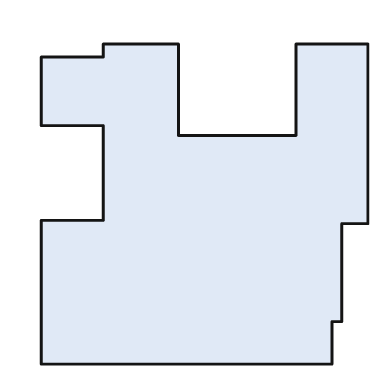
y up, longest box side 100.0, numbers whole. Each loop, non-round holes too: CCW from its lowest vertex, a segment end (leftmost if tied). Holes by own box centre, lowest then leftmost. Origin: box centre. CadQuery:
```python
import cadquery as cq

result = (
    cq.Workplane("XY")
    .moveTo(-50.0, -49.0)
    .lineTo(39.0, -49.0)
    .lineTo(39.0, -36.0)
    .lineTo(42.0, -36.0)
    .lineTo(42.0, -6.0)
    .lineTo(50.0, -6.0)
    .lineTo(50.0, 49.0)
    .lineTo(28.0, 49.0)
    .lineTo(28.0, 21.0)
    .lineTo(-8.0, 21.0)
    .lineTo(-8.0, 49.0)
    .lineTo(-31.0, 49.0)
    .lineTo(-31.0, 45.0)
    .lineTo(-50.0, 45.0)
    .lineTo(-50.0, 24.0)
    .lineTo(-31.0, 24.0)
    .lineTo(-31.0, -5.0)
    .lineTo(-50.0, -5.0)
    .close()
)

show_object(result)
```